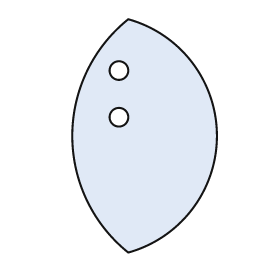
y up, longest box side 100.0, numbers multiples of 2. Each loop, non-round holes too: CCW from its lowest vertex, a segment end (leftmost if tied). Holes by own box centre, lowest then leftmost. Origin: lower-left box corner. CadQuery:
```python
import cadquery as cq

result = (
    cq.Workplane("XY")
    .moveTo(24.0, 0.0)
    .threePointArc((62.0, 50.0), (24.0, 100.0))
    .threePointArc((0.0, 50.0), (24.0, 0.0))
    .close()
    .moveTo(20.0, 58.0)
    .circle(4.0)
    .moveTo(20.0, 78.0)
    .circle(4.0)
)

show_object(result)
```